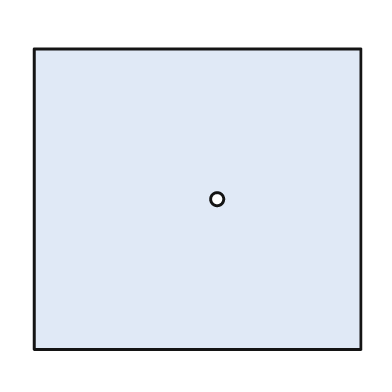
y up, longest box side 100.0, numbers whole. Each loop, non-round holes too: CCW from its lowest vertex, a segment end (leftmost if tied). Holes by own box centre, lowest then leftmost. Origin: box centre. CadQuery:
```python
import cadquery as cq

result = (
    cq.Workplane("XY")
    .moveTo(-50.0, -46.0)
    .lineTo(50.0, -46.0)
    .lineTo(50.0, 46.0)
    .lineTo(-50.0, 46.0)
    .close()
    .moveTo(6.0, 0.0)
    .circle(2.0)
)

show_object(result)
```